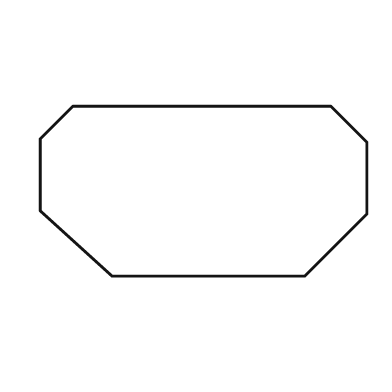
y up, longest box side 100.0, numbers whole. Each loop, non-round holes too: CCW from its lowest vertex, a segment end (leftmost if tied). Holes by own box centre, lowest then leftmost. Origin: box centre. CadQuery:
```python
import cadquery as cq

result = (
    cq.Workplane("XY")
    .moveTo(-28.0, -26.0)
    .lineTo(31.0, -26.0)
    .lineTo(50.0, -7.0)
    .lineTo(50.0, 15.0)
    .lineTo(39.0, 26.0)
    .lineTo(-40.0, 26.0)
    .lineTo(-50.0, 16.0)
    .lineTo(-50.0, -6.0)
    .close()
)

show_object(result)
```